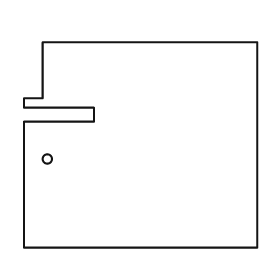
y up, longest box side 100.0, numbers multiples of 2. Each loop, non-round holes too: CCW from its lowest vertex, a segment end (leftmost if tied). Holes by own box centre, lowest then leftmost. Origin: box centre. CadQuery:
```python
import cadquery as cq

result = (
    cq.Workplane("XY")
    .moveTo(-50.0, -44.0)
    .lineTo(50.0, -44.0)
    .lineTo(50.0, 44.0)
    .lineTo(-42.0, 44.0)
    .lineTo(-42.0, 20.0)
    .lineTo(-50.0, 20.0)
    .lineTo(-50.0, 16.0)
    .lineTo(-20.0, 16.0)
    .lineTo(-20.0, 10.0)
    .lineTo(-50.0, 10.0)
    .close()
    .moveTo(-40.0, -6.0)
    .circle(2.0)
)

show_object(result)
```